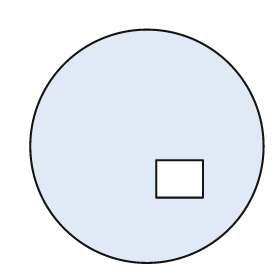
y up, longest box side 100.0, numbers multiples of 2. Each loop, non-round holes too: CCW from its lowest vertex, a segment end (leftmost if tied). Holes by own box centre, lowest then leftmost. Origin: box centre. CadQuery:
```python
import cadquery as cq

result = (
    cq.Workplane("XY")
    .moveTo(0.0, 0.0)
    .circle(50.0)
    .moveTo(4.0, -22.0)
    .lineTo(24.0, -22.0)
    .lineTo(24.0, -6.0)
    .lineTo(4.0, -6.0)
    .close()
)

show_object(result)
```